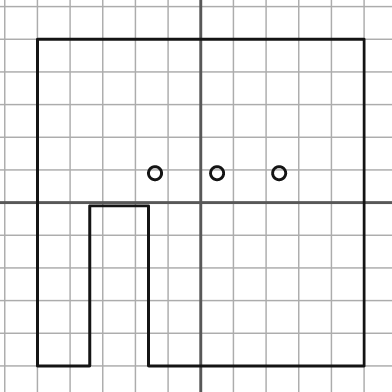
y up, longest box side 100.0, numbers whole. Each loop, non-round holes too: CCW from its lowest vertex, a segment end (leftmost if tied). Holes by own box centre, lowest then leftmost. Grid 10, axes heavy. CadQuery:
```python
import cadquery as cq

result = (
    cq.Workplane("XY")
    .moveTo(-50.0, -50.0)
    .lineTo(-34.0, -50.0)
    .lineTo(-34.0, -1.0)
    .lineTo(-16.0, -1.0)
    .lineTo(-16.0, -50.0)
    .lineTo(50.0, -50.0)
    .lineTo(50.0, 50.0)
    .lineTo(-50.0, 50.0)
    .close()
    .moveTo(-14.0, 9.0)
    .circle(2.0)
    .moveTo(5.0, 9.0)
    .circle(2.0)
    .moveTo(24.0, 9.0)
    .circle(2.0)
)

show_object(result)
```